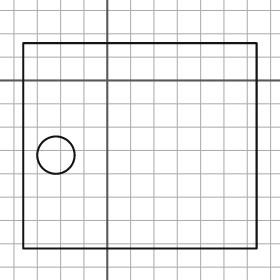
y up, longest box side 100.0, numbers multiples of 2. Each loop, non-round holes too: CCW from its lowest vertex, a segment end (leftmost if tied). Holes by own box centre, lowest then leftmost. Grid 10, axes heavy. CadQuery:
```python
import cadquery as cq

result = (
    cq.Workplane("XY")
    .moveTo(-36.0, -72.0)
    .lineTo(64.0, -72.0)
    .lineTo(64.0, 16.0)
    .lineTo(-36.0, 16.0)
    .close()
    .moveTo(-22.0, -32.0)
    .circle(8.0)
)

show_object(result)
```